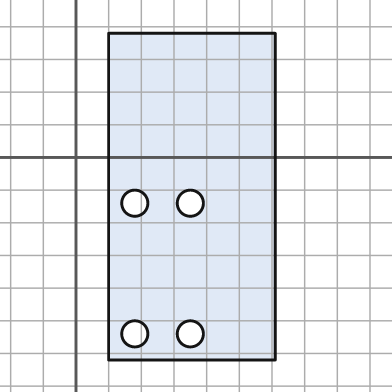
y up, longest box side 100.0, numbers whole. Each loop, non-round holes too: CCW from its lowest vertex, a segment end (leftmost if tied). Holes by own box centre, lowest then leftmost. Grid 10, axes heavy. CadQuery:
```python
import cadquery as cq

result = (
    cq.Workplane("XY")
    .moveTo(10.0, -62.0)
    .lineTo(61.0, -62.0)
    .lineTo(61.0, 38.0)
    .lineTo(10.0, 38.0)
    .close()
    .moveTo(18.0, -54.0)
    .circle(4.0)
    .moveTo(35.0, -54.0)
    .circle(4.0)
    .moveTo(18.0, -14.0)
    .circle(4.0)
    .moveTo(35.0, -14.0)
    .circle(4.0)
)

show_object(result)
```